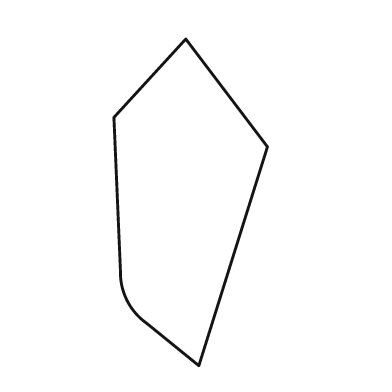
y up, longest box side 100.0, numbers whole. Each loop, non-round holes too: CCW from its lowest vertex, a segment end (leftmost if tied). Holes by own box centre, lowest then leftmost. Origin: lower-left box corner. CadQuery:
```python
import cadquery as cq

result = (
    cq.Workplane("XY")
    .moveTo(26.0, 0.0)
    .lineTo(47.0, 67.0)
    .lineTo(22.0, 100.0)
    .lineTo(0.0, 76.0)
    .lineTo(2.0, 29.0)
    .threePointArc((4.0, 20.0), (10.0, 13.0))
    .close()
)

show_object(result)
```